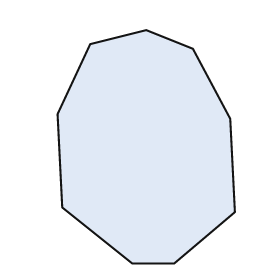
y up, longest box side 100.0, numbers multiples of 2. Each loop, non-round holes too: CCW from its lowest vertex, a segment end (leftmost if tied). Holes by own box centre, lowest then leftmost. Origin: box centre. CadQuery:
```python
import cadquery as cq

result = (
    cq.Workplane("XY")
    .moveTo(-6.0, -50.0)
    .lineTo(12.0, -50.0)
    .lineTo(38.0, -28.0)
    .lineTo(36.0, 12.0)
    .lineTo(20.0, 42.0)
    .lineTo(0.0, 50.0)
    .lineTo(-24.0, 44.0)
    .lineTo(-38.0, 14.0)
    .lineTo(-36.0, -26.0)
    .close()
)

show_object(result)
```